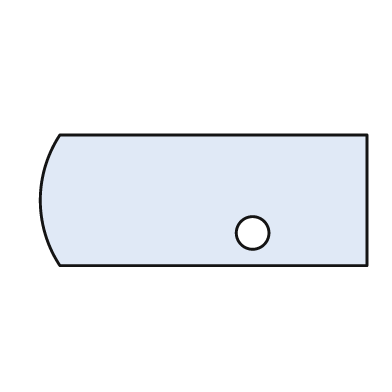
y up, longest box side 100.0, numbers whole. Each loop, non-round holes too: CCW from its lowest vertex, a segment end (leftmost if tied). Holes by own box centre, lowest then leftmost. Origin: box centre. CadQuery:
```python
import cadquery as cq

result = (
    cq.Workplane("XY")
    .moveTo(-44.0, -20.0)
    .lineTo(50.0, -20.0)
    .lineTo(50.0, 20.0)
    .lineTo(-44.0, 20.0)
    .threePointArc((-50.0, 0.0), (-44.0, -20.0))
    .close()
    .moveTo(15.0, -10.0)
    .circle(5.0)
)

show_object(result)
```